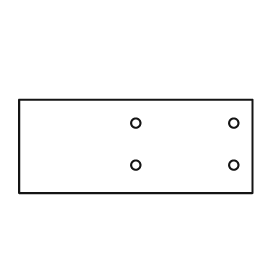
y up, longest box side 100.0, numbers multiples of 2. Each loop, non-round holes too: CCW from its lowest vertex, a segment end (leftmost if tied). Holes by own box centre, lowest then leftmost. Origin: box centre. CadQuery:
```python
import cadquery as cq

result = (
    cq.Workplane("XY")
    .moveTo(-50.0, -20.0)
    .lineTo(50.0, -20.0)
    .lineTo(50.0, 20.0)
    .lineTo(-50.0, 20.0)
    .close()
    .moveTo(0.0, -8.0)
    .circle(2.0)
    .moveTo(42.0, -8.0)
    .circle(2.0)
    .moveTo(0.0, 10.0)
    .circle(2.0)
    .moveTo(42.0, 10.0)
    .circle(2.0)
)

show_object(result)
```